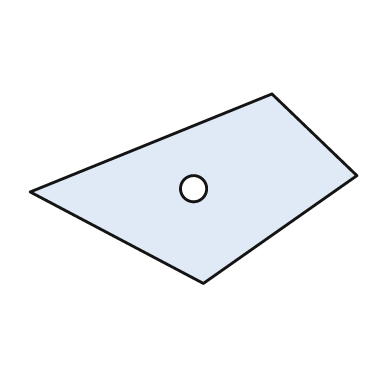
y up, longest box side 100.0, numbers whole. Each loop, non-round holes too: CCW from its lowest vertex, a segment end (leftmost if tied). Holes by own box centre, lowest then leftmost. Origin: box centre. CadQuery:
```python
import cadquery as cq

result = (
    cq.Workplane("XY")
    .moveTo(3.0, -29.0)
    .lineTo(50.0, 4.0)
    .lineTo(24.0, 29.0)
    .lineTo(-50.0, -1.0)
    .close()
    .moveTo(0.0, 0.0)
    .circle(4.0)
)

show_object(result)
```